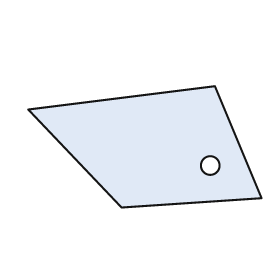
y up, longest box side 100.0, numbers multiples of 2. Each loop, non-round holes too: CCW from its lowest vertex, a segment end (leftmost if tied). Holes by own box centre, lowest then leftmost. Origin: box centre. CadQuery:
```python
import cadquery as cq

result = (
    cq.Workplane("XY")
    .moveTo(-10.0, -26.0)
    .lineTo(50.0, -22.0)
    .lineTo(30.0, 26.0)
    .lineTo(-50.0, 16.0)
    .close()
    .moveTo(28.0, -8.0)
    .circle(4.0)
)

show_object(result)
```